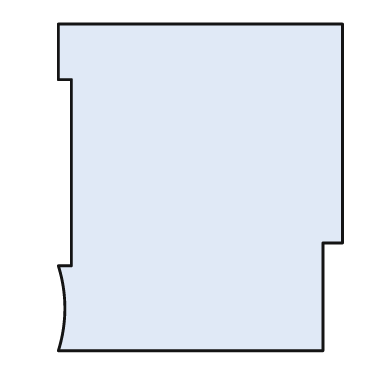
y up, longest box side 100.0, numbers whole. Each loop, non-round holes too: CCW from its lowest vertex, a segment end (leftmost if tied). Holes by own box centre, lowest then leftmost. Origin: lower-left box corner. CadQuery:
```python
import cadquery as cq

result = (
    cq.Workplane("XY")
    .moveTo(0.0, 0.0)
    .lineTo(81.0, 0.0)
    .lineTo(81.0, 33.0)
    .lineTo(87.0, 33.0)
    .lineTo(87.0, 100.0)
    .lineTo(0.0, 100.0)
    .lineTo(0.0, 83.0)
    .lineTo(4.0, 83.0)
    .lineTo(4.0, 26.0)
    .lineTo(0.0, 26.0)
    .threePointArc((2.0, 13.0), (0.0, 0.0))
    .close()
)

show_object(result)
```